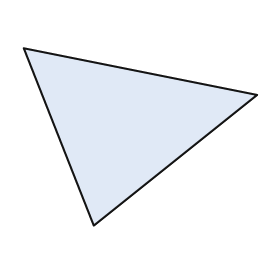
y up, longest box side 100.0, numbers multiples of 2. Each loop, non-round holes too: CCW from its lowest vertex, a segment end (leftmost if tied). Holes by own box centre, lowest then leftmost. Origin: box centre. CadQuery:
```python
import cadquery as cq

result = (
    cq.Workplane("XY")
    .moveTo(-20.0, -38.0)
    .lineTo(50.0, 18.0)
    .lineTo(-50.0, 38.0)
    .close()
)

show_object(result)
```